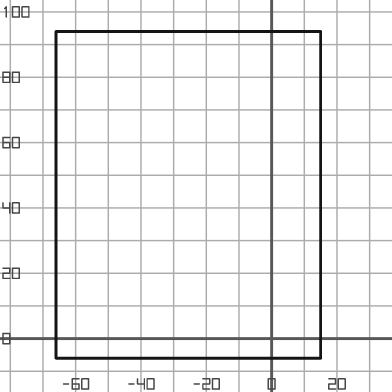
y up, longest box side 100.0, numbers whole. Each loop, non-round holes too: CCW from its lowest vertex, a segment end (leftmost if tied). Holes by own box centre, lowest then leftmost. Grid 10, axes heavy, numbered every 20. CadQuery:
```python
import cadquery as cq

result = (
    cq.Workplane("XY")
    .moveTo(-66.0, -6.0)
    .lineTo(15.0, -6.0)
    .lineTo(15.0, 94.0)
    .lineTo(-66.0, 94.0)
    .close()
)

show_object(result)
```